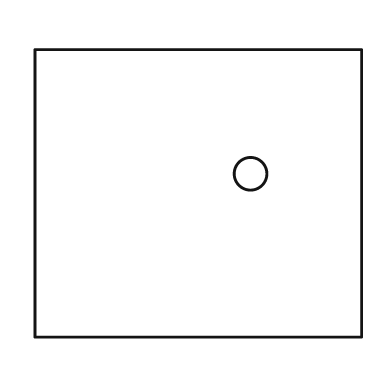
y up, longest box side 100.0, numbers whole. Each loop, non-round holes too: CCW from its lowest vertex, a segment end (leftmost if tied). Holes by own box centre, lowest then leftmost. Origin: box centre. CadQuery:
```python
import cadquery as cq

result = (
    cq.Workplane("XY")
    .moveTo(-50.0, -44.0)
    .lineTo(50.0, -44.0)
    .lineTo(50.0, 44.0)
    .lineTo(-50.0, 44.0)
    .close()
    .moveTo(16.0, 6.0)
    .circle(5.0)
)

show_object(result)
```